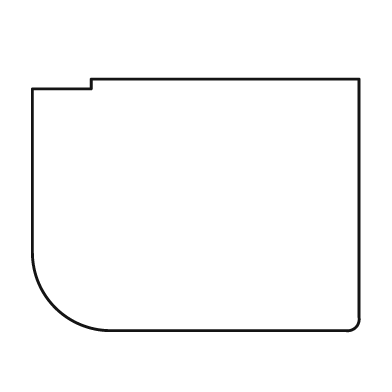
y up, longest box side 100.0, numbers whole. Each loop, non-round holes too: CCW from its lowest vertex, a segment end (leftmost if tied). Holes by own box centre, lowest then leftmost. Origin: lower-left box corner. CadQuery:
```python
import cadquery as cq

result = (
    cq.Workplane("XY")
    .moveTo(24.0, 0.0)
    .lineTo(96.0, 0.0)
    .threePointArc((99.0, 1.0), (100.0, 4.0))
    .lineTo(100.0, 77.0)
    .lineTo(18.0, 77.0)
    .lineTo(18.0, 74.0)
    .lineTo(0.0, 74.0)
    .lineTo(0.0, 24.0)
    .threePointArc((7.0, 7.0), (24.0, 0.0))
    .close()
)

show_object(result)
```